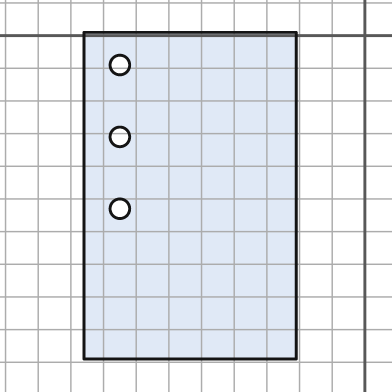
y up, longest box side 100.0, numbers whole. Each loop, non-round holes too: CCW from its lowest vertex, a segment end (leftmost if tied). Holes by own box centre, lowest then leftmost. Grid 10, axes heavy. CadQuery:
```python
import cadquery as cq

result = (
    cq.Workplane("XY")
    .moveTo(-86.0, -99.0)
    .lineTo(-21.0, -99.0)
    .lineTo(-21.0, 1.0)
    .lineTo(-86.0, 1.0)
    .close()
    .moveTo(-75.0, -53.0)
    .circle(3.0)
    .moveTo(-75.0, -31.0)
    .circle(3.0)
    .moveTo(-75.0, -9.0)
    .circle(3.0)
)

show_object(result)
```